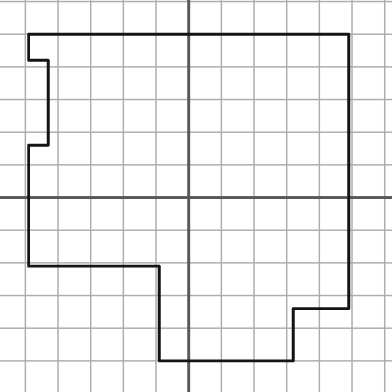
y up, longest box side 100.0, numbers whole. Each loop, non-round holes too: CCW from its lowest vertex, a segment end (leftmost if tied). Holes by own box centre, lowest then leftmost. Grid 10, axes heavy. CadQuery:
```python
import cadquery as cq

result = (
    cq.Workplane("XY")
    .moveTo(-9.0, -50.0)
    .lineTo(32.0, -50.0)
    .lineTo(32.0, -34.0)
    .lineTo(49.0, -34.0)
    .lineTo(49.0, 50.0)
    .lineTo(-49.0, 50.0)
    .lineTo(-49.0, 42.0)
    .lineTo(-43.0, 42.0)
    .lineTo(-43.0, 16.0)
    .lineTo(-49.0, 16.0)
    .lineTo(-49.0, -21.0)
    .lineTo(-9.0, -21.0)
    .close()
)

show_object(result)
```